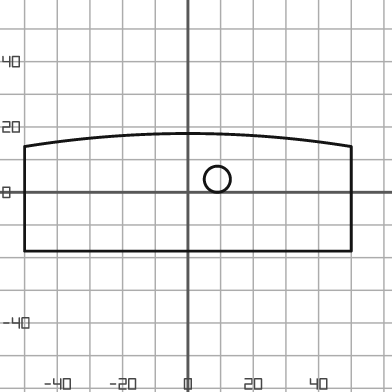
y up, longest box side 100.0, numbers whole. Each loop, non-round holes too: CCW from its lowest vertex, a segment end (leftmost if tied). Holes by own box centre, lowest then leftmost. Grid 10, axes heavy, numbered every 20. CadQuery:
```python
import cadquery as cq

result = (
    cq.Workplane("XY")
    .moveTo(-50.0, -18.0)
    .lineTo(50.0, -18.0)
    .lineTo(50.0, 14.0)
    .threePointArc((0.0, 18.0), (-50.0, 14.0))
    .close()
    .moveTo(9.0, 4.0)
    .circle(4.0)
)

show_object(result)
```